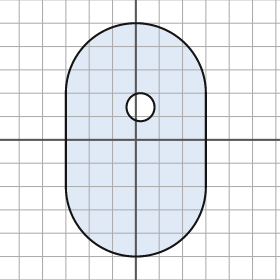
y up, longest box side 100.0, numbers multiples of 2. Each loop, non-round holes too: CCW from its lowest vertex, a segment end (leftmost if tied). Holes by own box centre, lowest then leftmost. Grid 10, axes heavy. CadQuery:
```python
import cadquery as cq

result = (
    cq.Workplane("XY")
    .moveTo(-30.0, -20.0)
    .threePointArc((0.0, -50.0), (30.0, -20.0))
    .lineTo(30.0, 20.0)
    .threePointArc((0.0, 50.0), (-30.0, 20.0))
    .close()
    .moveTo(2.0, 14.0)
    .circle(6.0)
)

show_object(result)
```